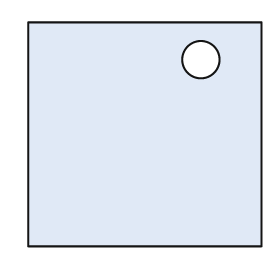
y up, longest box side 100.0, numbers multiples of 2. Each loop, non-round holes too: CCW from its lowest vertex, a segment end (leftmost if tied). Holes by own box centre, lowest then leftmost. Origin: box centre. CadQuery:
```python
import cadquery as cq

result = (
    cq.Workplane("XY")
    .moveTo(-50.0, -48.0)
    .lineTo(50.0, -48.0)
    .lineTo(50.0, 48.0)
    .lineTo(-50.0, 48.0)
    .close()
    .moveTo(24.0, 32.0)
    .circle(8.0)
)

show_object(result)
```